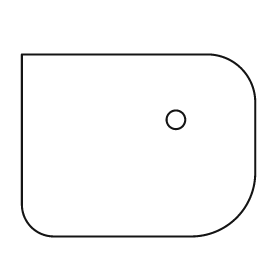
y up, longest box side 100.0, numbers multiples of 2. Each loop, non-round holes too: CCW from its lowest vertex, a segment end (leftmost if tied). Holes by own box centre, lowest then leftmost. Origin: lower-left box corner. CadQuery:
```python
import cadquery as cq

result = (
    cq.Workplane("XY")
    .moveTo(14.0, 0.0)
    .lineTo(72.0, 0.0)
    .threePointArc((92.0, 8.0), (100.0, 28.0))
    .lineTo(100.0, 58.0)
    .threePointArc((94.0, 72.0), (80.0, 78.0))
    .lineTo(0.0, 78.0)
    .lineTo(0.0, 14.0)
    .threePointArc((4.0, 4.0), (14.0, 0.0))
    .close()
    .moveTo(66.0, 50.0)
    .circle(4.0)
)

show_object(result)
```